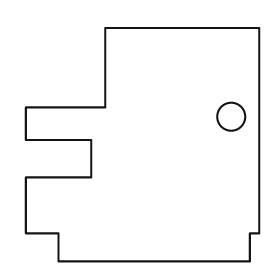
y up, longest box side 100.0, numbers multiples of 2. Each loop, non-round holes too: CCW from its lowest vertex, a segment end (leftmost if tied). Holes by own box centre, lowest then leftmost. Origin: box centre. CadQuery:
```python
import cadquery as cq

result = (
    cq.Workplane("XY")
    .moveTo(-36.0, -50.0)
    .lineTo(46.0, -50.0)
    .lineTo(46.0, -38.0)
    .lineTo(50.0, -38.0)
    .lineTo(50.0, 50.0)
    .lineTo(-16.0, 50.0)
    .lineTo(-16.0, 16.0)
    .lineTo(-50.0, 16.0)
    .lineTo(-50.0, 2.0)
    .lineTo(-22.0, 2.0)
    .lineTo(-22.0, -14.0)
    .lineTo(-50.0, -14.0)
    .lineTo(-50.0, -38.0)
    .lineTo(-36.0, -38.0)
    .close()
    .moveTo(38.0, 12.0)
    .circle(6.0)
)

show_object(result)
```